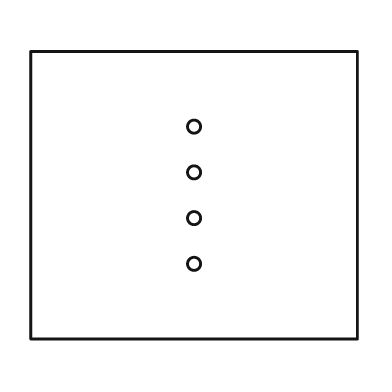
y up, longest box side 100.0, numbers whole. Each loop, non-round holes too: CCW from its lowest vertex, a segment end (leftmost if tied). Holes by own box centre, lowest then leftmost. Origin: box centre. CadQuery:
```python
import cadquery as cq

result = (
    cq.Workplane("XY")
    .moveTo(-50.0, -44.0)
    .lineTo(50.0, -44.0)
    .lineTo(50.0, 44.0)
    .lineTo(-50.0, 44.0)
    .close()
    .moveTo(0.0, -21.0)
    .circle(2.0)
    .moveTo(0.0, -7.0)
    .circle(2.0)
    .moveTo(0.0, 7.0)
    .circle(2.0)
    .moveTo(0.0, 21.0)
    .circle(2.0)
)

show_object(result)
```